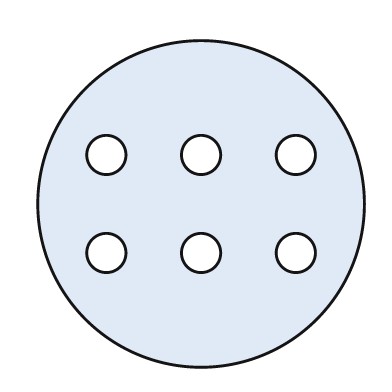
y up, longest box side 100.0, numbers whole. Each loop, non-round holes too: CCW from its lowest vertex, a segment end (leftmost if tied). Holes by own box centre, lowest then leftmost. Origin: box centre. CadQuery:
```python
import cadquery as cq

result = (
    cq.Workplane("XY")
    .moveTo(0.0, 0.0)
    .circle(50.0)
    .moveTo(-29.0, -15.0)
    .circle(6.0)
    .moveTo(0.0, -15.0)
    .circle(6.0)
    .moveTo(29.0, -15.0)
    .circle(6.0)
    .moveTo(-29.0, 15.0)
    .circle(6.0)
    .moveTo(0.0, 15.0)
    .circle(6.0)
    .moveTo(29.0, 15.0)
    .circle(6.0)
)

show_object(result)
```